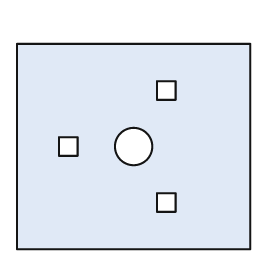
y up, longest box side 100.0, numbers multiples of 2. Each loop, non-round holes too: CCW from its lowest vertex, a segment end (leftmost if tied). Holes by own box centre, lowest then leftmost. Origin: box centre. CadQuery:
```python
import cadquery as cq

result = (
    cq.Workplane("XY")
    .moveTo(-50.0, -44.0)
    .lineTo(50.0, -44.0)
    .lineTo(50.0, 44.0)
    .lineTo(-50.0, 44.0)
    .close()
    .moveTo(10.0, -28.0)
    .lineTo(18.0, -28.0)
    .lineTo(18.0, -20.0)
    .lineTo(10.0, -20.0)
    .close()
    .moveTo(-32.0, -4.0)
    .lineTo(-24.0, -4.0)
    .lineTo(-24.0, 4.0)
    .lineTo(-32.0, 4.0)
    .close()
    .moveTo(0.0, 0.0)
    .circle(8.0)
    .moveTo(10.0, 20.0)
    .lineTo(18.0, 20.0)
    .lineTo(18.0, 28.0)
    .lineTo(10.0, 28.0)
    .close()
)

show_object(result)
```